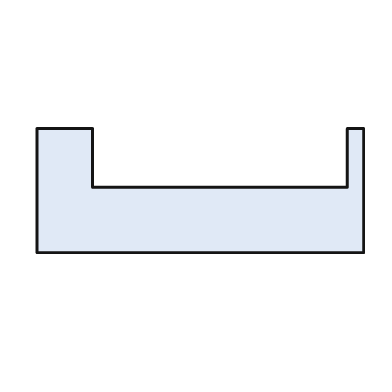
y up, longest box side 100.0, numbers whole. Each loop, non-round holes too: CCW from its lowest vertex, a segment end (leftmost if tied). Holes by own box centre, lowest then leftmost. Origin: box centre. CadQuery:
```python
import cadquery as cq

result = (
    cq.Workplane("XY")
    .moveTo(-50.0, -19.0)
    .lineTo(50.0, -19.0)
    .lineTo(50.0, 19.0)
    .lineTo(45.0, 19.0)
    .lineTo(45.0, 1.0)
    .lineTo(-33.0, 1.0)
    .lineTo(-33.0, 19.0)
    .lineTo(-50.0, 19.0)
    .close()
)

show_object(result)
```